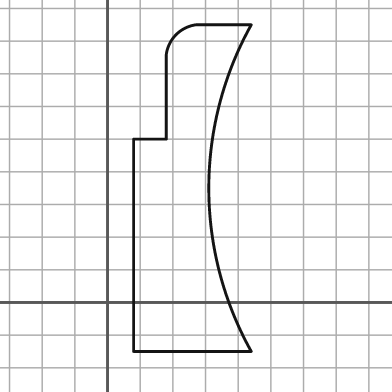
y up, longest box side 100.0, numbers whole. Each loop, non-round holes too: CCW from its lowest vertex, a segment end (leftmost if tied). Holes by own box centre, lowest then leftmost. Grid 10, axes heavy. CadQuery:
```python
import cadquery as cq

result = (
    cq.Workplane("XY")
    .moveTo(8.0, -15.0)
    .lineTo(44.0, -15.0)
    .threePointArc((31.0, 35.0), (44.0, 85.0))
    .lineTo(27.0, 85.0)
    .threePointArc((21.0, 82.0), (18.0, 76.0))
    .lineTo(18.0, 50.0)
    .lineTo(8.0, 50.0)
    .close()
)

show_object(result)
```